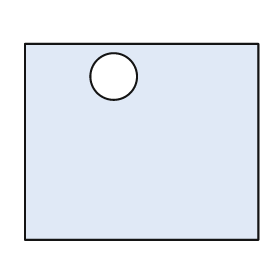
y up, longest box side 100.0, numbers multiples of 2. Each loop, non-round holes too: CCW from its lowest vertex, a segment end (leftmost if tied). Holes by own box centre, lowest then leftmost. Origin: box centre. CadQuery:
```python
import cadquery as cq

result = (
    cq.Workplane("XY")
    .moveTo(-50.0, -42.0)
    .lineTo(50.0, -42.0)
    .lineTo(50.0, 42.0)
    .lineTo(-50.0, 42.0)
    .close()
    .moveTo(-12.0, 28.0)
    .circle(10.0)
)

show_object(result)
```